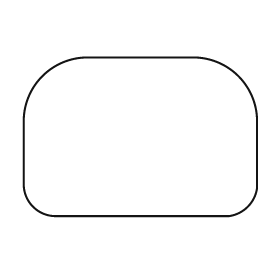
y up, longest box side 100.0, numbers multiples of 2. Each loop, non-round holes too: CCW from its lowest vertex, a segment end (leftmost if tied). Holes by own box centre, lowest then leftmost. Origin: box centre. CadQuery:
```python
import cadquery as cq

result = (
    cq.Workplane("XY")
    .moveTo(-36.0, -34.0)
    .lineTo(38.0, -34.0)
    .threePointArc((46.0, -30.0), (50.0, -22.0))
    .lineTo(50.0, 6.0)
    .threePointArc((42.0, 26.0), (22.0, 34.0))
    .lineTo(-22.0, 34.0)
    .threePointArc((-42.0, 26.0), (-50.0, 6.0))
    .lineTo(-50.0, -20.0)
    .threePointArc((-46.0, -30.0), (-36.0, -34.0))
    .close()
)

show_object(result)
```